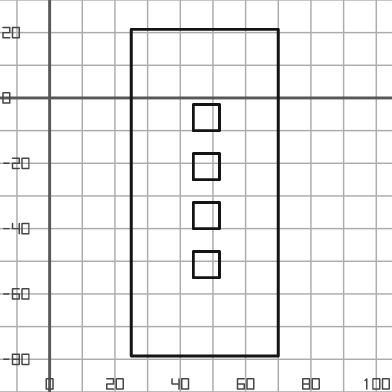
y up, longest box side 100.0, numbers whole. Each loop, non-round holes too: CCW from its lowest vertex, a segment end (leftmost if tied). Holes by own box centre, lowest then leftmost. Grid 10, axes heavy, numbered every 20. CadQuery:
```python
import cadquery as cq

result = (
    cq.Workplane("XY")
    .moveTo(25.0, -79.0)
    .lineTo(70.0, -79.0)
    .lineTo(70.0, 21.0)
    .lineTo(25.0, 21.0)
    .close()
    .moveTo(44.0, -55.0)
    .lineTo(52.0, -55.0)
    .lineTo(52.0, -47.0)
    .lineTo(44.0, -47.0)
    .close()
    .moveTo(44.0, -40.0)
    .lineTo(52.0, -40.0)
    .lineTo(52.0, -32.0)
    .lineTo(44.0, -32.0)
    .close()
    .moveTo(44.0, -25.0)
    .lineTo(52.0, -25.0)
    .lineTo(52.0, -17.0)
    .lineTo(44.0, -17.0)
    .close()
    .moveTo(44.0, -10.0)
    .lineTo(52.0, -10.0)
    .lineTo(52.0, -2.0)
    .lineTo(44.0, -2.0)
    .close()
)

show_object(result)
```